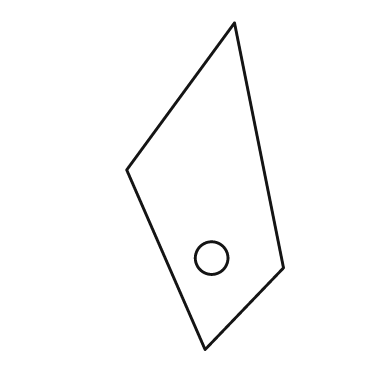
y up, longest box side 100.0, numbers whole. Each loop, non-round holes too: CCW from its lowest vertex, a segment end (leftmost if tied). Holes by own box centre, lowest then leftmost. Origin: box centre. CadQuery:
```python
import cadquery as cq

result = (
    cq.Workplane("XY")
    .moveTo(0.0, -50.0)
    .lineTo(24.0, -25.0)
    .lineTo(9.0, 50.0)
    .lineTo(-24.0, 5.0)
    .close()
    .moveTo(2.0, -22.0)
    .circle(5.0)
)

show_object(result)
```